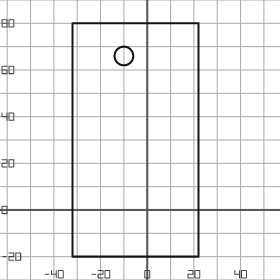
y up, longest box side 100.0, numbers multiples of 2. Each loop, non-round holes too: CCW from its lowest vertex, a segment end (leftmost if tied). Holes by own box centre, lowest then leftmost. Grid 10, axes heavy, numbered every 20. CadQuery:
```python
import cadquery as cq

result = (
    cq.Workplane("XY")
    .moveTo(-32.0, -20.0)
    .lineTo(22.0, -20.0)
    .lineTo(22.0, 80.0)
    .lineTo(-32.0, 80.0)
    .close()
    .moveTo(-10.0, 66.0)
    .circle(4.0)
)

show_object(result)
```